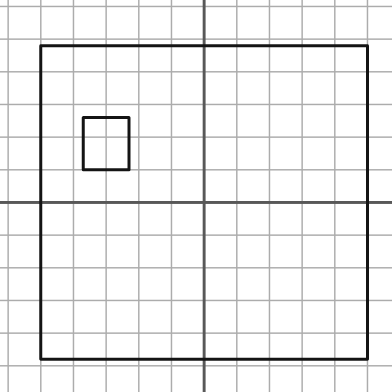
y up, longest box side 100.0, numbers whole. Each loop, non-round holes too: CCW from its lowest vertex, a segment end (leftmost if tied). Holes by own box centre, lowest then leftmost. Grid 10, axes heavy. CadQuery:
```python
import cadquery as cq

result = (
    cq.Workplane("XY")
    .moveTo(-50.0, -48.0)
    .lineTo(50.0, -48.0)
    .lineTo(50.0, 48.0)
    .lineTo(-50.0, 48.0)
    .close()
    .moveTo(-37.0, 10.0)
    .lineTo(-23.0, 10.0)
    .lineTo(-23.0, 26.0)
    .lineTo(-37.0, 26.0)
    .close()
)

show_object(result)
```